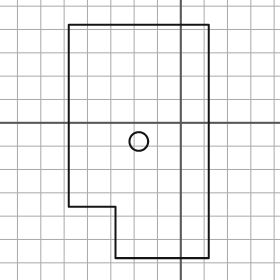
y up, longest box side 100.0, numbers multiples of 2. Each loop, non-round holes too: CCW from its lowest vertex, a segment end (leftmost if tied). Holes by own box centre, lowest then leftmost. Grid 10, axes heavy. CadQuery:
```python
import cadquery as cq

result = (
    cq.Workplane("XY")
    .moveTo(-28.0, -58.0)
    .lineTo(12.0, -58.0)
    .lineTo(12.0, 42.0)
    .lineTo(-48.0, 42.0)
    .lineTo(-48.0, -36.0)
    .lineTo(-28.0, -36.0)
    .close()
    .moveTo(-18.0, -8.0)
    .circle(4.0)
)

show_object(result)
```